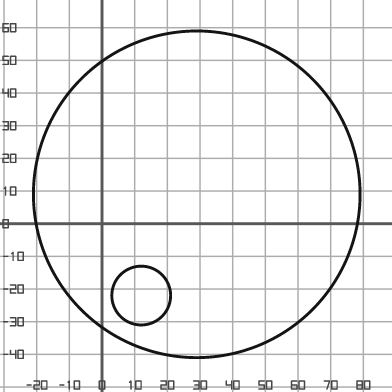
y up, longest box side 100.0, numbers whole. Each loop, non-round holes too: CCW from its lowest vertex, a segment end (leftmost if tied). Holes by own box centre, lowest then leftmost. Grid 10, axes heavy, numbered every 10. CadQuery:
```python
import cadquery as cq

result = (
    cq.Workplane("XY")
    .moveTo(29.0, 9.0)
    .circle(50.0)
    .moveTo(12.0, -22.0)
    .circle(9.0)
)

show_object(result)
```